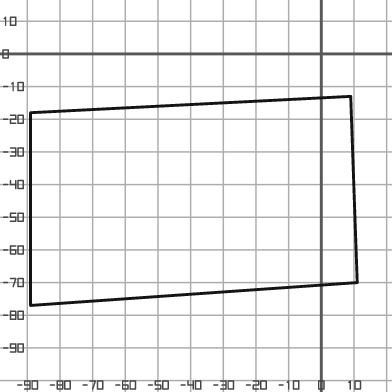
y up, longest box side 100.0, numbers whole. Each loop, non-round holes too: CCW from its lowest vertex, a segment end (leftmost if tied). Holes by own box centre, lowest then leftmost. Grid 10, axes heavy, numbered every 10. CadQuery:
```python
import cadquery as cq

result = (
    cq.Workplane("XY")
    .moveTo(-89.0, -77.0)
    .lineTo(11.0, -70.0)
    .lineTo(9.0, -13.0)
    .lineTo(-89.0, -18.0)
    .close()
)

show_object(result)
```